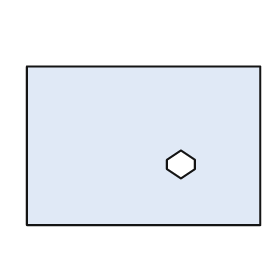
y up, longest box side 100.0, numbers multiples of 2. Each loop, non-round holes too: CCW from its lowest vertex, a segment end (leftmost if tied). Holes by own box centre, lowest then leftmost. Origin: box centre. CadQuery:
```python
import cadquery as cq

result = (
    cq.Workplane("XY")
    .moveTo(-50.0, -34.0)
    .lineTo(50.0, -34.0)
    .lineTo(50.0, 34.0)
    .lineTo(-50.0, 34.0)
    .close()
    .moveTo(16.0, -14.0)
    .lineTo(22.0, -10.0)
    .lineTo(22.0, -6.0)
    .lineTo(16.0, -2.0)
    .lineTo(10.0, -6.0)
    .lineTo(10.0, -10.0)
    .close()
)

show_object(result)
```